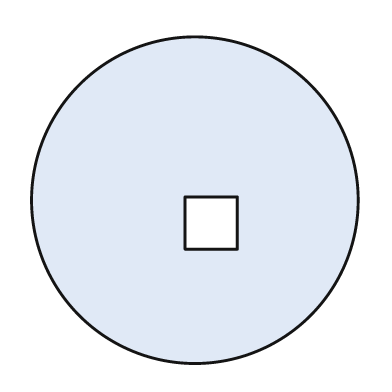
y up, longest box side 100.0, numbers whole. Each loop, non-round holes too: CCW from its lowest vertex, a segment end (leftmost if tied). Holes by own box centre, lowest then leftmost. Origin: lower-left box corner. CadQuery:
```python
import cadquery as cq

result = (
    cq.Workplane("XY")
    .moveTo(50.0, 50.0)
    .circle(50.0)
    .moveTo(47.0, 35.0)
    .lineTo(63.0, 35.0)
    .lineTo(63.0, 51.0)
    .lineTo(47.0, 51.0)
    .close()
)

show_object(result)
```